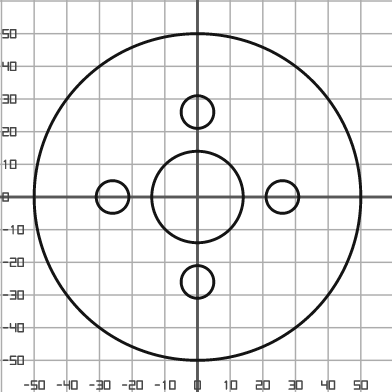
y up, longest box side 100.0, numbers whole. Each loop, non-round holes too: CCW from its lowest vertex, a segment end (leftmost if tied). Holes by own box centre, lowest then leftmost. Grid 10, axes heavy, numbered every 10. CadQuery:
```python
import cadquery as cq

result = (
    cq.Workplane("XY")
    .moveTo(0.0, 0.0)
    .circle(50.0)
    .moveTo(0.0, -26.0)
    .circle(5.0)
    .moveTo(-26.0, 0.0)
    .circle(5.0)
    .moveTo(0.0, 0.0)
    .circle(14.0)
    .moveTo(26.0, 0.0)
    .circle(5.0)
    .moveTo(0.0, 26.0)
    .circle(5.0)
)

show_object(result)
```